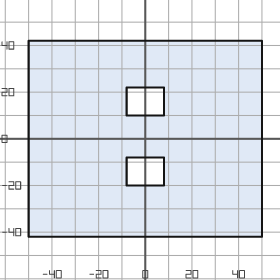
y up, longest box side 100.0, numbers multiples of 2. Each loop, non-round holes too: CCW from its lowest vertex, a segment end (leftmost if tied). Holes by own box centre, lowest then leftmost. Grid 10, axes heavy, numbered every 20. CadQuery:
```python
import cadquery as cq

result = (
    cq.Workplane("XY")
    .moveTo(-50.0, -42.0)
    .lineTo(50.0, -42.0)
    .lineTo(50.0, 42.0)
    .lineTo(-50.0, 42.0)
    .close()
    .moveTo(-8.0, -20.0)
    .lineTo(8.0, -20.0)
    .lineTo(8.0, -8.0)
    .lineTo(-8.0, -8.0)
    .close()
    .moveTo(-8.0, 10.0)
    .lineTo(8.0, 10.0)
    .lineTo(8.0, 22.0)
    .lineTo(-8.0, 22.0)
    .close()
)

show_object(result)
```